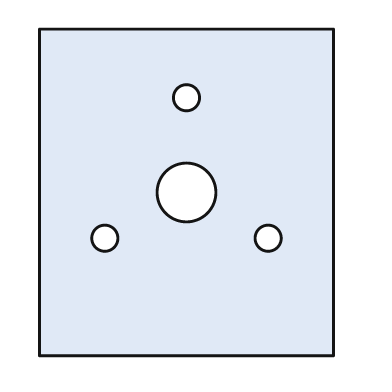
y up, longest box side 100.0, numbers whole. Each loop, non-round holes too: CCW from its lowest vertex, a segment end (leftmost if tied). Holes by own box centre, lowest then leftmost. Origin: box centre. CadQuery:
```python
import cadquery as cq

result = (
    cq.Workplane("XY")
    .moveTo(-45.0, -50.0)
    .lineTo(45.0, -50.0)
    .lineTo(45.0, 50.0)
    .lineTo(-45.0, 50.0)
    .close()
    .moveTo(-25.0, -14.0)
    .circle(4.0)
    .moveTo(25.0, -14.0)
    .circle(4.0)
    .moveTo(0.0, 0.0)
    .circle(9.0)
    .moveTo(0.0, 29.0)
    .circle(4.0)
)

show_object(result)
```